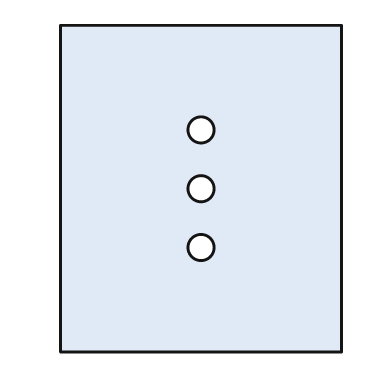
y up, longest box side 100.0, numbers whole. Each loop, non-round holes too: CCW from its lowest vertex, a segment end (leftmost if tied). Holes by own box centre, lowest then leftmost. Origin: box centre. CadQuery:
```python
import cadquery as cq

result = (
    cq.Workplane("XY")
    .moveTo(-43.0, -50.0)
    .lineTo(43.0, -50.0)
    .lineTo(43.0, 50.0)
    .lineTo(-43.0, 50.0)
    .close()
    .moveTo(0.0, -18.0)
    .circle(4.0)
    .moveTo(0.0, 0.0)
    .circle(4.0)
    .moveTo(0.0, 18.0)
    .circle(4.0)
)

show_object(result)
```